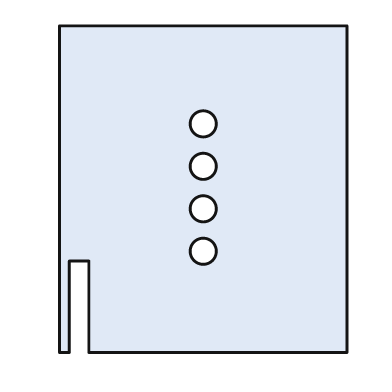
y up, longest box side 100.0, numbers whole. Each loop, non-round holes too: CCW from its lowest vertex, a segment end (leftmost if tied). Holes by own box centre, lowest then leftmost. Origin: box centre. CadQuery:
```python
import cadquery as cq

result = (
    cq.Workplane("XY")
    .moveTo(-44.0, -50.0)
    .lineTo(-41.0, -50.0)
    .lineTo(-41.0, -22.0)
    .lineTo(-35.0, -22.0)
    .lineTo(-35.0, -50.0)
    .lineTo(44.0, -50.0)
    .lineTo(44.0, 50.0)
    .lineTo(-44.0, 50.0)
    .close()
    .moveTo(0.0, -19.0)
    .circle(4.0)
    .moveTo(0.0, -6.0)
    .circle(4.0)
    .moveTo(0.0, 7.0)
    .circle(4.0)
    .moveTo(0.0, 20.0)
    .circle(4.0)
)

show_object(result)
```